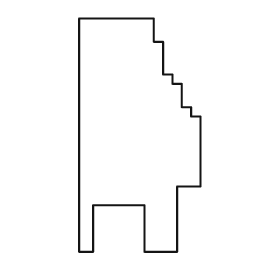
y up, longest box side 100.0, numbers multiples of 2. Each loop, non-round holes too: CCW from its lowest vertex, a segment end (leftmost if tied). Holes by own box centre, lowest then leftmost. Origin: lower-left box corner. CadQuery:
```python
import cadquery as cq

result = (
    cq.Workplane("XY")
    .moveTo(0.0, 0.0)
    .lineTo(6.0, 0.0)
    .lineTo(6.0, 20.0)
    .lineTo(28.0, 20.0)
    .lineTo(28.0, 0.0)
    .lineTo(42.0, 0.0)
    .lineTo(42.0, 28.0)
    .lineTo(52.0, 28.0)
    .lineTo(52.0, 58.0)
    .lineTo(48.0, 58.0)
    .lineTo(48.0, 62.0)
    .lineTo(44.0, 62.0)
    .lineTo(44.0, 72.0)
    .lineTo(40.0, 72.0)
    .lineTo(40.0, 76.0)
    .lineTo(36.0, 76.0)
    .lineTo(36.0, 90.0)
    .lineTo(32.0, 90.0)
    .lineTo(32.0, 100.0)
    .lineTo(0.0, 100.0)
    .close()
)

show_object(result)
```